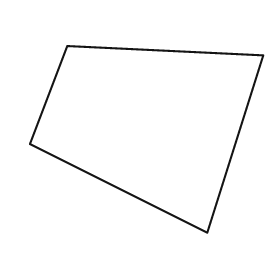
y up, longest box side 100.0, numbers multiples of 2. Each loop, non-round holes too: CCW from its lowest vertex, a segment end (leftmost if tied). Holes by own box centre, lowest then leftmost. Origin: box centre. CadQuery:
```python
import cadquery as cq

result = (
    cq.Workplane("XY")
    .moveTo(26.0, -40.0)
    .lineTo(50.0, 36.0)
    .lineTo(-34.0, 40.0)
    .lineTo(-50.0, -2.0)
    .close()
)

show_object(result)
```